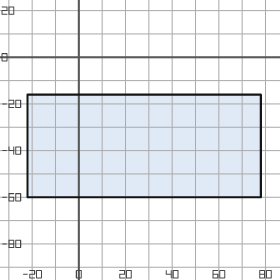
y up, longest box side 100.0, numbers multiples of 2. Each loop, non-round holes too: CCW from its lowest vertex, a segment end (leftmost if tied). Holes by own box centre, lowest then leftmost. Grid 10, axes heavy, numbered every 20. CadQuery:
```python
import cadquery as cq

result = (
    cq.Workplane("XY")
    .moveTo(-22.0, -60.0)
    .lineTo(78.0, -60.0)
    .lineTo(78.0, -16.0)
    .lineTo(-22.0, -16.0)
    .close()
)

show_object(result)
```